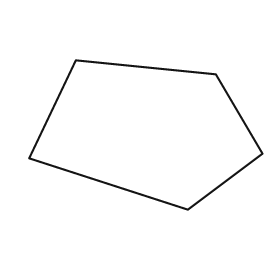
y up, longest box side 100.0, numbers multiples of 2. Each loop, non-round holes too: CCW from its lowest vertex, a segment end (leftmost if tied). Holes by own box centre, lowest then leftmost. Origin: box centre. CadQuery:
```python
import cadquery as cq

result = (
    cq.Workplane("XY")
    .moveTo(18.0, -32.0)
    .lineTo(50.0, -8.0)
    .lineTo(30.0, 26.0)
    .lineTo(-30.0, 32.0)
    .lineTo(-50.0, -10.0)
    .close()
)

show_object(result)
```